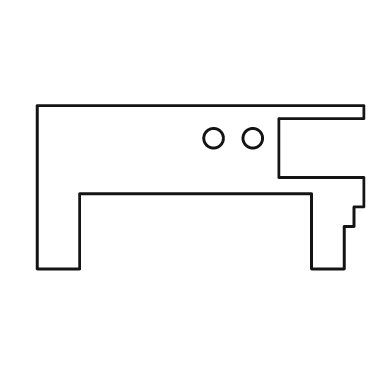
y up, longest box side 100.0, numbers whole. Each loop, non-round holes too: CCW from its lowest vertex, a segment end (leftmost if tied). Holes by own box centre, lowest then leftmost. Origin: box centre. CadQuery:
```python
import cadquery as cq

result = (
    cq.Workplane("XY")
    .moveTo(-50.0, -25.0)
    .lineTo(-37.0, -25.0)
    .lineTo(-37.0, -2.0)
    .lineTo(34.0, -2.0)
    .lineTo(34.0, -25.0)
    .lineTo(44.0, -25.0)
    .lineTo(44.0, -12.0)
    .lineTo(47.0, -12.0)
    .lineTo(47.0, -6.0)
    .lineTo(50.0, -6.0)
    .lineTo(50.0, 3.0)
    .lineTo(24.0, 3.0)
    .lineTo(24.0, 21.0)
    .lineTo(50.0, 21.0)
    .lineTo(50.0, 25.0)
    .lineTo(-50.0, 25.0)
    .close()
    .moveTo(4.0, 15.0)
    .circle(3.0)
    .moveTo(16.0, 15.0)
    .circle(3.0)
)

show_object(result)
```